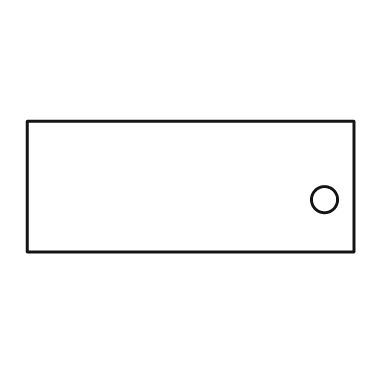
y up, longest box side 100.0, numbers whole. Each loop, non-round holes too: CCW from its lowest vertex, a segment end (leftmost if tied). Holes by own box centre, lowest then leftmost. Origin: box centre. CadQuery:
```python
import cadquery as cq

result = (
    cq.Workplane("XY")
    .moveTo(-50.0, -20.0)
    .lineTo(50.0, -20.0)
    .lineTo(50.0, 20.0)
    .lineTo(-50.0, 20.0)
    .close()
    .moveTo(41.0, -4.0)
    .circle(4.0)
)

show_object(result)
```